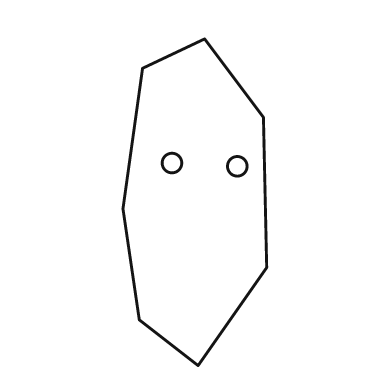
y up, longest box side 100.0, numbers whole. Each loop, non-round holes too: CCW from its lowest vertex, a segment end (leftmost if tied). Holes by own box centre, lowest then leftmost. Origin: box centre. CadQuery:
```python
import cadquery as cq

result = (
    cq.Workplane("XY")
    .moveTo(1.0, -50.0)
    .lineTo(22.0, -20.0)
    .lineTo(21.0, 26.0)
    .lineTo(3.0, 50.0)
    .lineTo(-16.0, 41.0)
    .lineTo(-22.0, -2.0)
    .lineTo(-17.0, -36.0)
    .close()
    .moveTo(13.0, 11.0)
    .circle(3.0)
    .moveTo(-7.0, 12.0)
    .circle(3.0)
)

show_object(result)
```